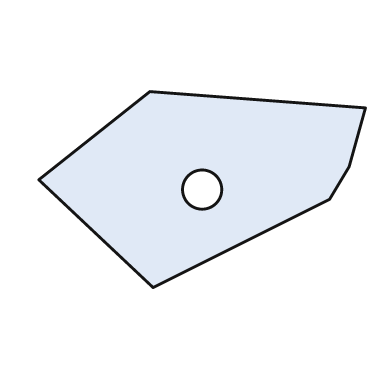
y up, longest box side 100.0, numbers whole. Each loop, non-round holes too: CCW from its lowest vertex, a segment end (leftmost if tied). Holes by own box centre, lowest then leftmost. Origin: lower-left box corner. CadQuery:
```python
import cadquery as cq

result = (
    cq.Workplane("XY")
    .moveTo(35.0, 0.0)
    .lineTo(89.0, 27.0)
    .lineTo(95.0, 37.0)
    .lineTo(100.0, 55.0)
    .lineTo(34.0, 60.0)
    .lineTo(0.0, 33.0)
    .close()
    .moveTo(50.0, 30.0)
    .circle(6.0)
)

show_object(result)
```